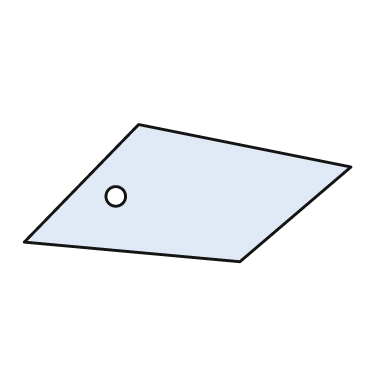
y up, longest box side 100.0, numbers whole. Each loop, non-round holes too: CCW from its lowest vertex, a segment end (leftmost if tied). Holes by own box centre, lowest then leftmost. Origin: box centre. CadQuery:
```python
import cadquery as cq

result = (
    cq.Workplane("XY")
    .moveTo(16.0, -21.0)
    .lineTo(50.0, 8.0)
    .lineTo(-15.0, 21.0)
    .lineTo(-50.0, -15.0)
    .close()
    .moveTo(-22.0, -1.0)
    .circle(3.0)
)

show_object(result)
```